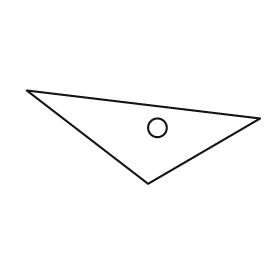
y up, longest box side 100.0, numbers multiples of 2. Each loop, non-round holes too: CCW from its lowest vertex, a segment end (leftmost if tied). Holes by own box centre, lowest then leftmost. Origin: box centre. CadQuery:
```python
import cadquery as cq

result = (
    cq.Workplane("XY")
    .moveTo(2.0, -20.0)
    .lineTo(50.0, 8.0)
    .lineTo(-50.0, 20.0)
    .close()
    .moveTo(6.0, 4.0)
    .circle(4.0)
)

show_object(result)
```